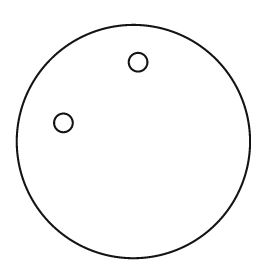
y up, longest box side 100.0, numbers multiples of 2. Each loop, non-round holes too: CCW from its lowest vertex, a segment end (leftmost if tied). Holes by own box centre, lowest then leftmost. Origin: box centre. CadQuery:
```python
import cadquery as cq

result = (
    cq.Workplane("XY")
    .moveTo(0.0, 0.0)
    .circle(50.0)
    .moveTo(-30.0, 8.0)
    .circle(4.0)
    .moveTo(2.0, 34.0)
    .circle(4.0)
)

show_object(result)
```